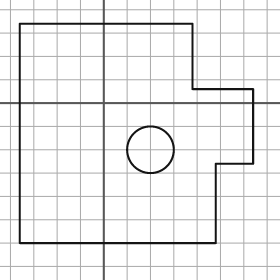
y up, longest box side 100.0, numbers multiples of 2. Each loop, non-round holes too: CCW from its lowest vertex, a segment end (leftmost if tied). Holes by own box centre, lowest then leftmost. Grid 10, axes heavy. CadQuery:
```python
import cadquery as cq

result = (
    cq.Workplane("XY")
    .moveTo(-36.0, -60.0)
    .lineTo(48.0, -60.0)
    .lineTo(48.0, -26.0)
    .lineTo(64.0, -26.0)
    .lineTo(64.0, 6.0)
    .lineTo(38.0, 6.0)
    .lineTo(38.0, 34.0)
    .lineTo(-36.0, 34.0)
    .close()
    .moveTo(20.0, -20.0)
    .circle(10.0)
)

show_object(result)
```